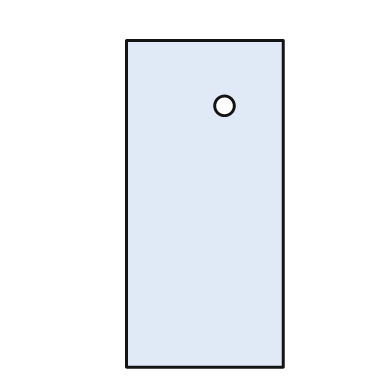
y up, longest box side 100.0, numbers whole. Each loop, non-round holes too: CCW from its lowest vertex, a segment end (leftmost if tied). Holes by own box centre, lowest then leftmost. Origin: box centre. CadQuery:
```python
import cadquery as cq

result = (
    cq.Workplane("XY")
    .moveTo(-24.0, -50.0)
    .lineTo(24.0, -50.0)
    .lineTo(24.0, 50.0)
    .lineTo(-24.0, 50.0)
    .close()
    .moveTo(6.0, 30.0)
    .circle(3.0)
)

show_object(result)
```